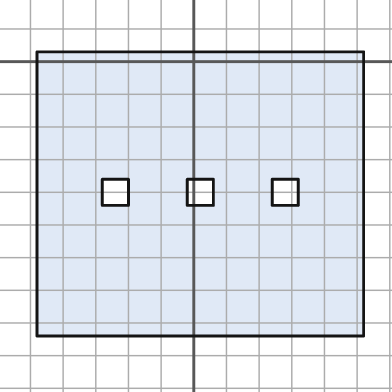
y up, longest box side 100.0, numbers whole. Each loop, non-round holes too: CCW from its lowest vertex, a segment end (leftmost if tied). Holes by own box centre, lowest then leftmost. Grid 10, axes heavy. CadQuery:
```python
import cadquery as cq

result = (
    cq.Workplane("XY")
    .moveTo(-48.0, -84.0)
    .lineTo(52.0, -84.0)
    .lineTo(52.0, 3.0)
    .lineTo(-48.0, 3.0)
    .close()
    .moveTo(-28.0, -44.0)
    .lineTo(-20.0, -44.0)
    .lineTo(-20.0, -36.0)
    .lineTo(-28.0, -36.0)
    .close()
    .moveTo(-2.0, -44.0)
    .lineTo(6.0, -44.0)
    .lineTo(6.0, -36.0)
    .lineTo(-2.0, -36.0)
    .close()
    .moveTo(24.0, -44.0)
    .lineTo(32.0, -44.0)
    .lineTo(32.0, -36.0)
    .lineTo(24.0, -36.0)
    .close()
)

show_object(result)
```